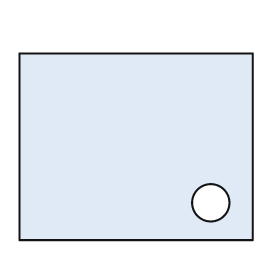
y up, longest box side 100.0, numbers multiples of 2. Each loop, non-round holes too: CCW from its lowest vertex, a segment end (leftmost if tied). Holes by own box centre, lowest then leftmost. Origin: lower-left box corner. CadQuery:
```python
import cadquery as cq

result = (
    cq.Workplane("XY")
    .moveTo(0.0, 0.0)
    .lineTo(100.0, 0.0)
    .lineTo(100.0, 80.0)
    .lineTo(0.0, 80.0)
    .close()
    .moveTo(82.0, 16.0)
    .circle(8.0)
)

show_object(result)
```